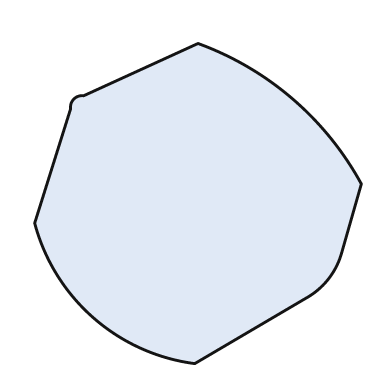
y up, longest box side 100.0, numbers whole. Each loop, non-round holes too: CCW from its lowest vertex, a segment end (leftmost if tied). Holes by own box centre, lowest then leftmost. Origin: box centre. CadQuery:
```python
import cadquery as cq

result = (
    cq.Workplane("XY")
    .moveTo(-1.0, -49.0)
    .lineTo(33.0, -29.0)
    .threePointArc((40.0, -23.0), (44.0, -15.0))
    .lineTo(50.0, 6.0)
    .threePointArc((29.0, 32.0), (0.0, 49.0))
    .lineTo(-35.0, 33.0)
    .threePointArc((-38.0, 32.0), (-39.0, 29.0))
    .lineTo(-50.0, -6.0)
    .threePointArc((-32.0, -35.0), (-1.0, -49.0))
    .close()
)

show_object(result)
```